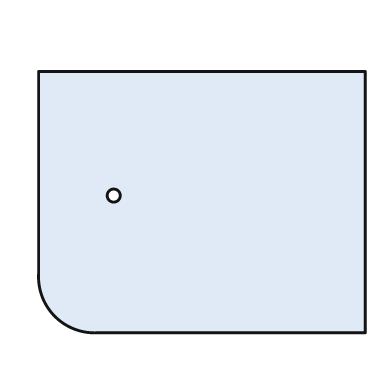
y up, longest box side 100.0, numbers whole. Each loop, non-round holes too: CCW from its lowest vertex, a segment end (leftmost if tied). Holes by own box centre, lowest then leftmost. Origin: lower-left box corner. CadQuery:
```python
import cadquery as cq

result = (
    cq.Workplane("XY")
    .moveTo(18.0, 0.0)
    .lineTo(100.0, 0.0)
    .lineTo(100.0, 80.0)
    .lineTo(0.0, 80.0)
    .lineTo(0.0, 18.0)
    .threePointArc((5.0, 5.0), (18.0, 0.0))
    .close()
    .moveTo(23.0, 42.0)
    .circle(2.0)
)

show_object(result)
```